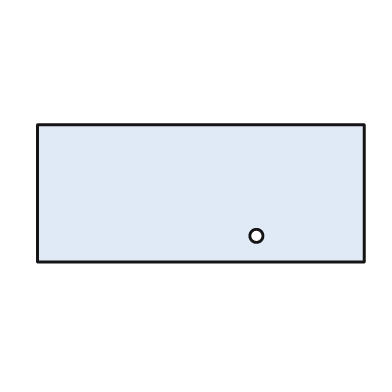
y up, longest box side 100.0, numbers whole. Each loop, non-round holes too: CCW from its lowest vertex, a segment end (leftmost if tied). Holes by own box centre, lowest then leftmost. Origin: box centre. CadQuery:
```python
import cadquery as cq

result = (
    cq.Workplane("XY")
    .moveTo(-50.0, -21.0)
    .lineTo(50.0, -21.0)
    .lineTo(50.0, 21.0)
    .lineTo(-50.0, 21.0)
    .close()
    .moveTo(17.0, -13.0)
    .circle(2.0)
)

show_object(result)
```